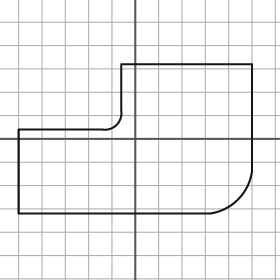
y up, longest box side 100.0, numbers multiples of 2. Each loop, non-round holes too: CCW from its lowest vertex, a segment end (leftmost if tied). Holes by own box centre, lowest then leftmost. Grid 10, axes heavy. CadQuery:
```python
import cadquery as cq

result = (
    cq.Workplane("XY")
    .moveTo(-50.0, -32.0)
    .lineTo(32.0, -32.0)
    .threePointArc((44.0, -26.0), (50.0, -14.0))
    .lineTo(50.0, 32.0)
    .lineTo(-6.0, 32.0)
    .lineTo(-6.0, 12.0)
    .threePointArc((-8.0, 6.0), (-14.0, 4.0))
    .lineTo(-50.0, 4.0)
    .close()
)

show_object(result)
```